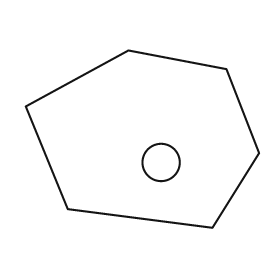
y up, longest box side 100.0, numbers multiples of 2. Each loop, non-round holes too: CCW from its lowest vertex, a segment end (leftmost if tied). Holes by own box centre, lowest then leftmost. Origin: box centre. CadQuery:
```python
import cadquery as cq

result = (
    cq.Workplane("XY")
    .moveTo(30.0, -38.0)
    .lineTo(50.0, -6.0)
    .lineTo(36.0, 30.0)
    .lineTo(-6.0, 38.0)
    .lineTo(-50.0, 14.0)
    .lineTo(-32.0, -30.0)
    .close()
    .moveTo(8.0, -10.0)
    .circle(8.0)
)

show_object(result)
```